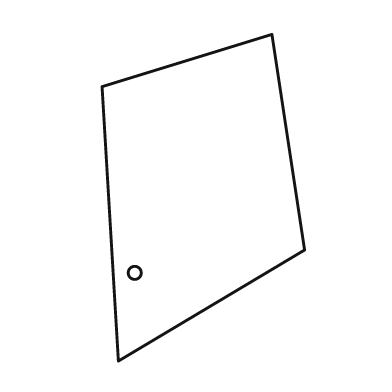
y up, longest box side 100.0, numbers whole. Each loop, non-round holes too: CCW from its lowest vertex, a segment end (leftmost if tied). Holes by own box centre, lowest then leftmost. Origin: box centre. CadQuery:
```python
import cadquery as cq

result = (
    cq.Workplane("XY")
    .moveTo(-26.0, -50.0)
    .lineTo(31.0, -16.0)
    .lineTo(21.0, 50.0)
    .lineTo(-31.0, 34.0)
    .close()
    .moveTo(-21.0, -23.0)
    .circle(2.0)
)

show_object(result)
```